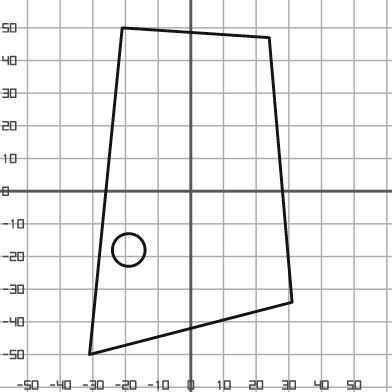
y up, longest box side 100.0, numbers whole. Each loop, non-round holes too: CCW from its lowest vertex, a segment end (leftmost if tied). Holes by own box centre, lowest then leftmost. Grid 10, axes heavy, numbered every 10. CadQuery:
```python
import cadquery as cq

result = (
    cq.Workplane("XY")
    .moveTo(-31.0, -50.0)
    .lineTo(31.0, -34.0)
    .lineTo(24.0, 47.0)
    .lineTo(-21.0, 50.0)
    .close()
    .moveTo(-19.0, -18.0)
    .circle(5.0)
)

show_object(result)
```